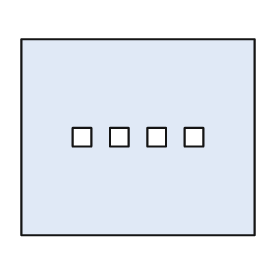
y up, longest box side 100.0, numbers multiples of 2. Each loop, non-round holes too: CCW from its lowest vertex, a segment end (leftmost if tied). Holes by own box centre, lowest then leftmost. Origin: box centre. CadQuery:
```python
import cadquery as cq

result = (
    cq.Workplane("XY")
    .moveTo(-50.0, -42.0)
    .lineTo(50.0, -42.0)
    .lineTo(50.0, 42.0)
    .lineTo(-50.0, 42.0)
    .close()
    .moveTo(-28.0, -4.0)
    .lineTo(-20.0, -4.0)
    .lineTo(-20.0, 4.0)
    .lineTo(-28.0, 4.0)
    .close()
    .moveTo(-12.0, -4.0)
    .lineTo(-4.0, -4.0)
    .lineTo(-4.0, 4.0)
    .lineTo(-12.0, 4.0)
    .close()
    .moveTo(4.0, -4.0)
    .lineTo(12.0, -4.0)
    .lineTo(12.0, 4.0)
    .lineTo(4.0, 4.0)
    .close()
    .moveTo(20.0, -4.0)
    .lineTo(28.0, -4.0)
    .lineTo(28.0, 4.0)
    .lineTo(20.0, 4.0)
    .close()
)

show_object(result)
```